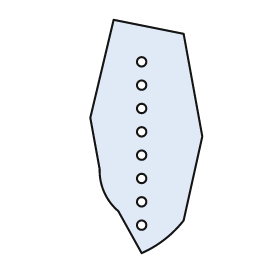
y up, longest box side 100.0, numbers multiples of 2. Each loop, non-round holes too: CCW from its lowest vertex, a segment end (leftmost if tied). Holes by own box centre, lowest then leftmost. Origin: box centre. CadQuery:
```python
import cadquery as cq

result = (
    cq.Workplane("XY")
    .moveTo(-2.0, -50.0)
    .threePointArc((8.0, -44.0), (16.0, -36.0))
    .lineTo(24.0, 0.0)
    .lineTo(16.0, 44.0)
    .lineTo(-14.0, 50.0)
    .lineTo(-24.0, 8.0)
    .lineTo(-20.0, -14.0)
    .threePointArc((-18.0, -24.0), (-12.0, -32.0))
    .close()
    .moveTo(-2.0, -38.0)
    .circle(2.0)
    .moveTo(-2.0, -28.0)
    .circle(2.0)
    .moveTo(-2.0, -18.0)
    .circle(2.0)
    .moveTo(-2.0, -8.0)
    .circle(2.0)
    .moveTo(-2.0, 2.0)
    .circle(2.0)
    .moveTo(-2.0, 12.0)
    .circle(2.0)
    .moveTo(-2.0, 22.0)
    .circle(2.0)
    .moveTo(-2.0, 32.0)
    .circle(2.0)
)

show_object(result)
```